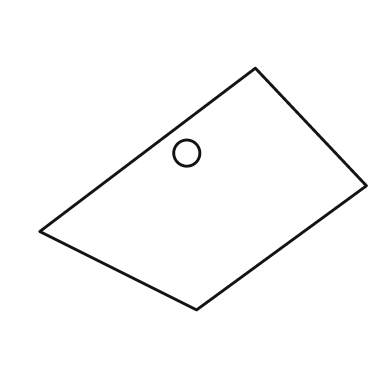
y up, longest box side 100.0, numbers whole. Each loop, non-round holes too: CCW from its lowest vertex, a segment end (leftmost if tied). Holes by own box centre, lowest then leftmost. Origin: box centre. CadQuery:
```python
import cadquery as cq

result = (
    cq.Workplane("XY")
    .moveTo(-2.0, -37.0)
    .lineTo(50.0, 1.0)
    .lineTo(16.0, 37.0)
    .lineTo(-50.0, -13.0)
    .close()
    .moveTo(-5.0, 11.0)
    .circle(4.0)
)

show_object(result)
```